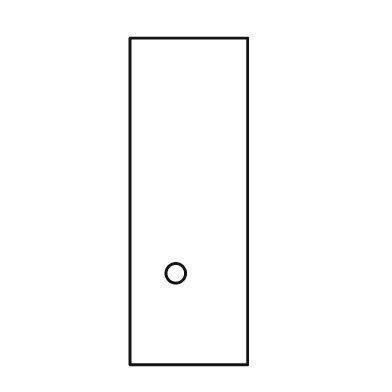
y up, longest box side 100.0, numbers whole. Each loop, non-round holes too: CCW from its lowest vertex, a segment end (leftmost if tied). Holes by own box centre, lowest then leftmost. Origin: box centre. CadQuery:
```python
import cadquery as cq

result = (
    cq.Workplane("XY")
    .moveTo(-18.0, -50.0)
    .lineTo(18.0, -50.0)
    .lineTo(18.0, 50.0)
    .lineTo(-18.0, 50.0)
    .close()
    .moveTo(-4.0, -22.0)
    .circle(3.0)
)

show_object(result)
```